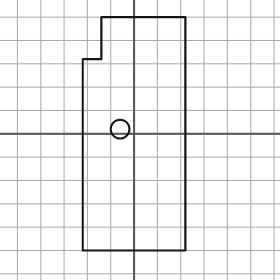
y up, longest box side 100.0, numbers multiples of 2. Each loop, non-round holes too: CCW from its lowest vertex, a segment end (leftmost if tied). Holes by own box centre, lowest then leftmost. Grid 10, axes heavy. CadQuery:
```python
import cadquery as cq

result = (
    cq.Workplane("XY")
    .moveTo(-22.0, -50.0)
    .lineTo(22.0, -50.0)
    .lineTo(22.0, 50.0)
    .lineTo(-14.0, 50.0)
    .lineTo(-14.0, 32.0)
    .lineTo(-22.0, 32.0)
    .close()
    .moveTo(-6.0, 2.0)
    .circle(4.0)
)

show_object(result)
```